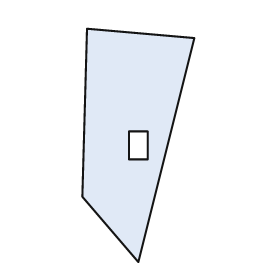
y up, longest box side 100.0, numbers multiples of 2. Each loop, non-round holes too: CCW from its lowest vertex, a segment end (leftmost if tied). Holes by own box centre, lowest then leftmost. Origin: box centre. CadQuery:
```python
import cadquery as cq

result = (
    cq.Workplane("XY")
    .moveTo(0.0, -50.0)
    .lineTo(24.0, 46.0)
    .lineTo(-22.0, 50.0)
    .lineTo(-24.0, -22.0)
    .close()
    .moveTo(-4.0, -6.0)
    .lineTo(4.0, -6.0)
    .lineTo(4.0, 6.0)
    .lineTo(-4.0, 6.0)
    .close()
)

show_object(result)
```